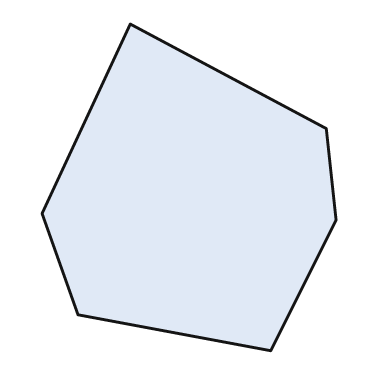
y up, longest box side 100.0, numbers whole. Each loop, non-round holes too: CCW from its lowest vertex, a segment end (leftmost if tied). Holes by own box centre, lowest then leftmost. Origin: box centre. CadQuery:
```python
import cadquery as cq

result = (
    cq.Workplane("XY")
    .moveTo(25.0, -50.0)
    .lineTo(45.0, -10.0)
    .lineTo(42.0, 18.0)
    .lineTo(-18.0, 50.0)
    .lineTo(-45.0, -8.0)
    .lineTo(-34.0, -39.0)
    .close()
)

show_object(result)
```